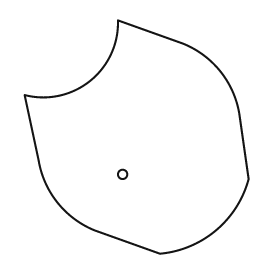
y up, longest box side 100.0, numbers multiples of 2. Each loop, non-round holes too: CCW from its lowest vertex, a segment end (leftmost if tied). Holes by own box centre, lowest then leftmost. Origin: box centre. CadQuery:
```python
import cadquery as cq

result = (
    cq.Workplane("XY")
    .moveTo(10.0, -50.0)
    .threePointArc((34.0, -40.0), (48.0, -18.0))
    .lineTo(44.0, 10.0)
    .threePointArc((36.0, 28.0), (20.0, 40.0))
    .lineTo(-8.0, 50.0)
    .threePointArc((-20.0, 24.0), (-48.0, 18.0))
    .lineTo(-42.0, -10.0)
    .threePointArc((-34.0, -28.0), (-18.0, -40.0))
    .close()
    .moveTo(-6.0, -16.0)
    .circle(2.0)
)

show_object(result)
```